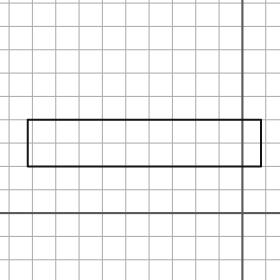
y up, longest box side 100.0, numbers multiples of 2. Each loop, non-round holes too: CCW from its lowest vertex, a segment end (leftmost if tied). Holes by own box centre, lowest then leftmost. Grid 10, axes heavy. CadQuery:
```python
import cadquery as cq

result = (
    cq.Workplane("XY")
    .moveTo(-92.0, 20.0)
    .lineTo(8.0, 20.0)
    .lineTo(8.0, 40.0)
    .lineTo(-92.0, 40.0)
    .close()
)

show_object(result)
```